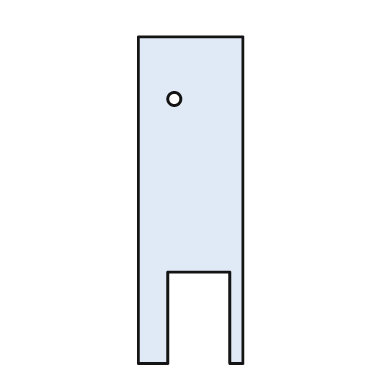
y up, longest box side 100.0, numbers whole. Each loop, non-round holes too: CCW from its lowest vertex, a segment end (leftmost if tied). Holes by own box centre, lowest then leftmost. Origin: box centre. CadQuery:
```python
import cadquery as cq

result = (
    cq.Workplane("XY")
    .moveTo(-16.0, -50.0)
    .lineTo(-7.0, -50.0)
    .lineTo(-7.0, -22.0)
    .lineTo(12.0, -22.0)
    .lineTo(12.0, -50.0)
    .lineTo(16.0, -50.0)
    .lineTo(16.0, 50.0)
    .lineTo(-16.0, 50.0)
    .close()
    .moveTo(-5.0, 31.0)
    .circle(2.0)
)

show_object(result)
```